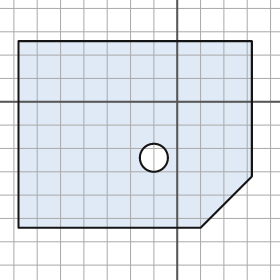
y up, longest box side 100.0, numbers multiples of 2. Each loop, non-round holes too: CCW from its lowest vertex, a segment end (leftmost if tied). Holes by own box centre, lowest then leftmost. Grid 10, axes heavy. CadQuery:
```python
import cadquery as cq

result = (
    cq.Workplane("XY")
    .moveTo(-68.0, -54.0)
    .lineTo(10.0, -54.0)
    .lineTo(32.0, -32.0)
    .lineTo(32.0, 26.0)
    .lineTo(-68.0, 26.0)
    .close()
    .moveTo(-10.0, -24.0)
    .circle(6.0)
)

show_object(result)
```